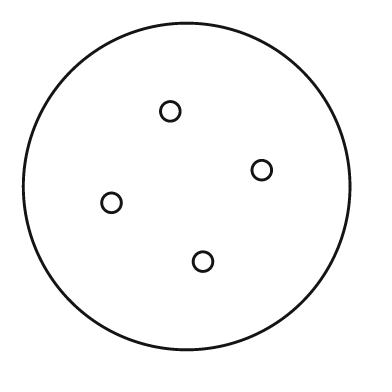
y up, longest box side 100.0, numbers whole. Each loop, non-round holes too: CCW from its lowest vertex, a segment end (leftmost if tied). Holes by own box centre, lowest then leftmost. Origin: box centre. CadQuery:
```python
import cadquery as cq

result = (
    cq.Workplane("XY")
    .moveTo(0.0, 0.0)
    .circle(50.0)
    .moveTo(5.0, -23.0)
    .circle(3.0)
    .moveTo(-23.0, -5.0)
    .circle(3.0)
    .moveTo(23.0, 5.0)
    .circle(3.0)
    .moveTo(-5.0, 23.0)
    .circle(3.0)
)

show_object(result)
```